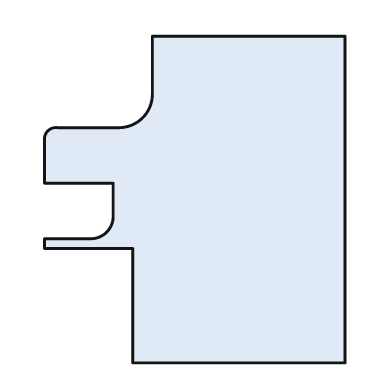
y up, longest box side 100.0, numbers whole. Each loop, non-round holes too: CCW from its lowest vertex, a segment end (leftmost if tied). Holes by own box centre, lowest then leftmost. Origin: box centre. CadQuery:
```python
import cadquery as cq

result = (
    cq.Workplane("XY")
    .moveTo(-19.0, -50.0)
    .lineTo(46.0, -50.0)
    .lineTo(46.0, 50.0)
    .lineTo(-13.0, 50.0)
    .lineTo(-13.0, 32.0)
    .threePointArc((-16.0, 25.0), (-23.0, 22.0))
    .lineTo(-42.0, 22.0)
    .threePointArc((-45.0, 21.0), (-46.0, 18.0))
    .lineTo(-46.0, 5.0)
    .lineTo(-25.0, 5.0)
    .lineTo(-25.0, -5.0)
    .threePointArc((-27.0, -10.0), (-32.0, -12.0))
    .lineTo(-46.0, -12.0)
    .lineTo(-46.0, -15.0)
    .lineTo(-19.0, -15.0)
    .close()
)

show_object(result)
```